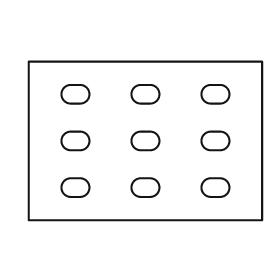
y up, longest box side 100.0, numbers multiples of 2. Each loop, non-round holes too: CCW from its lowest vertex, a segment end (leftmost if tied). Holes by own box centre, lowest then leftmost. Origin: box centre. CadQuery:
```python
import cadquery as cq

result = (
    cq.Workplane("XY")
    .moveTo(-50.0, -34.0)
    .lineTo(50.0, -34.0)
    .lineTo(50.0, 34.0)
    .lineTo(-50.0, 34.0)
    .close()
    .moveTo(-32.0, -24.0)
    .lineTo(-28.0, -24.0)
    .threePointArc((-24.0, -20.0), (-28.0, -16.0))
    .lineTo(-32.0, -16.0)
    .threePointArc((-36.0, -20.0), (-32.0, -24.0))
    .close()
    .moveTo(-2.0, -24.0)
    .lineTo(2.0, -24.0)
    .threePointArc((6.0, -20.0), (2.0, -16.0))
    .lineTo(-2.0, -16.0)
    .threePointArc((-6.0, -20.0), (-2.0, -24.0))
    .close()
    .moveTo(28.0, -24.0)
    .lineTo(32.0, -24.0)
    .threePointArc((36.0, -20.0), (32.0, -16.0))
    .lineTo(28.0, -16.0)
    .threePointArc((24.0, -20.0), (28.0, -24.0))
    .close()
    .moveTo(-32.0, -4.0)
    .lineTo(-28.0, -4.0)
    .threePointArc((-24.0, 0.0), (-28.0, 4.0))
    .lineTo(-32.0, 4.0)
    .threePointArc((-36.0, 0.0), (-32.0, -4.0))
    .close()
    .moveTo(-2.0, -4.0)
    .lineTo(2.0, -4.0)
    .threePointArc((6.0, 0.0), (2.0, 4.0))
    .lineTo(-2.0, 4.0)
    .threePointArc((-6.0, 0.0), (-2.0, -4.0))
    .close()
    .moveTo(28.0, -4.0)
    .lineTo(32.0, -4.0)
    .threePointArc((36.0, 0.0), (32.0, 4.0))
    .lineTo(28.0, 4.0)
    .threePointArc((24.0, 0.0), (28.0, -4.0))
    .close()
    .moveTo(-32.0, 16.0)
    .lineTo(-28.0, 16.0)
    .threePointArc((-24.0, 20.0), (-28.0, 24.0))
    .lineTo(-32.0, 24.0)
    .threePointArc((-36.0, 20.0), (-32.0, 16.0))
    .close()
    .moveTo(-2.0, 16.0)
    .lineTo(2.0, 16.0)
    .threePointArc((6.0, 20.0), (2.0, 24.0))
    .lineTo(-2.0, 24.0)
    .threePointArc((-6.0, 20.0), (-2.0, 16.0))
    .close()
    .moveTo(28.0, 16.0)
    .lineTo(32.0, 16.0)
    .threePointArc((36.0, 20.0), (32.0, 24.0))
    .lineTo(28.0, 24.0)
    .threePointArc((24.0, 20.0), (28.0, 16.0))
    .close()
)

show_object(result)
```